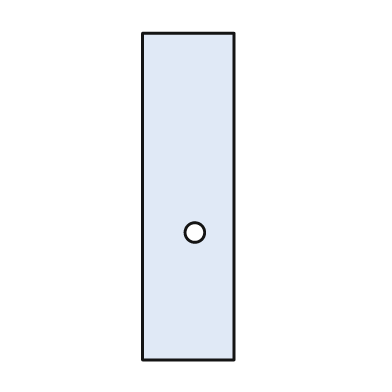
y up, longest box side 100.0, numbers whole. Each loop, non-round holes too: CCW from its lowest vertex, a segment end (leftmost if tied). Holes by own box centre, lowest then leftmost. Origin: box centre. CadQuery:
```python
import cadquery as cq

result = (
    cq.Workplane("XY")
    .moveTo(-14.0, -50.0)
    .lineTo(14.0, -50.0)
    .lineTo(14.0, 50.0)
    .lineTo(-14.0, 50.0)
    .close()
    .moveTo(2.0, -11.0)
    .circle(3.0)
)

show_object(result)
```